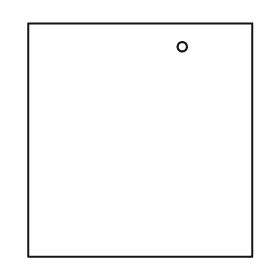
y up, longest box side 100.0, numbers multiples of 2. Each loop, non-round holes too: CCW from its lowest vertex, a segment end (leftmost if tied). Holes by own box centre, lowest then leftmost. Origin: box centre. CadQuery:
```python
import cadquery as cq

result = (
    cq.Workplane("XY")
    .moveTo(-48.0, -50.0)
    .lineTo(48.0, -50.0)
    .lineTo(48.0, 50.0)
    .lineTo(-48.0, 50.0)
    .close()
    .moveTo(18.0, 40.0)
    .circle(2.0)
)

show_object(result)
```